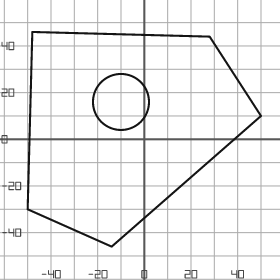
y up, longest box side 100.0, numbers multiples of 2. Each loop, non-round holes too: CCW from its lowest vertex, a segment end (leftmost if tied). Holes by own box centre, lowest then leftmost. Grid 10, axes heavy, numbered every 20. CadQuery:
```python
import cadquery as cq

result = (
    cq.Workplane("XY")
    .moveTo(-14.0, -46.0)
    .lineTo(50.0, 10.0)
    .lineTo(28.0, 44.0)
    .lineTo(-48.0, 46.0)
    .lineTo(-50.0, -30.0)
    .close()
    .moveTo(-10.0, 16.0)
    .circle(12.0)
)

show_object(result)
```